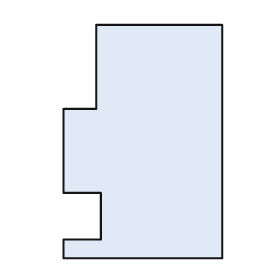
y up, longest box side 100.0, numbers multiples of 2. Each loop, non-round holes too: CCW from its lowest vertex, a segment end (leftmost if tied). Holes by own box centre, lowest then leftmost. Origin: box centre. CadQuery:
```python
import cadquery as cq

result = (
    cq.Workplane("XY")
    .moveTo(-34.0, -50.0)
    .lineTo(34.0, -50.0)
    .lineTo(34.0, 50.0)
    .lineTo(-20.0, 50.0)
    .lineTo(-20.0, 14.0)
    .lineTo(-34.0, 14.0)
    .lineTo(-34.0, -22.0)
    .lineTo(-18.0, -22.0)
    .lineTo(-18.0, -42.0)
    .lineTo(-34.0, -42.0)
    .close()
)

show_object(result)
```